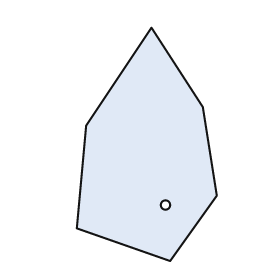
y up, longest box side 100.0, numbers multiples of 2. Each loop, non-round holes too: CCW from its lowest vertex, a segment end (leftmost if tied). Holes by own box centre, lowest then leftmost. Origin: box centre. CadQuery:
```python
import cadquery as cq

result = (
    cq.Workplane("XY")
    .moveTo(10.0, -50.0)
    .lineTo(30.0, -22.0)
    .lineTo(24.0, 16.0)
    .lineTo(2.0, 50.0)
    .lineTo(-26.0, 8.0)
    .lineTo(-30.0, -36.0)
    .close()
    .moveTo(8.0, -26.0)
    .circle(2.0)
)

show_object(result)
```